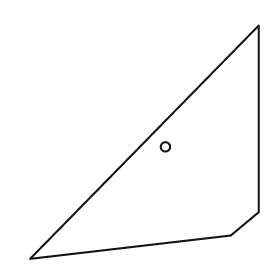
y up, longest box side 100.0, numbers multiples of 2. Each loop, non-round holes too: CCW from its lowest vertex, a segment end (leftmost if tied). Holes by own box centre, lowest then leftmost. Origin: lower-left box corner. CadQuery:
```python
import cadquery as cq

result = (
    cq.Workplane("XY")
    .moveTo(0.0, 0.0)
    .lineTo(86.0, 10.0)
    .lineTo(98.0, 20.0)
    .lineTo(98.0, 100.0)
    .close()
    .moveTo(58.0, 48.0)
    .circle(2.0)
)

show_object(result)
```